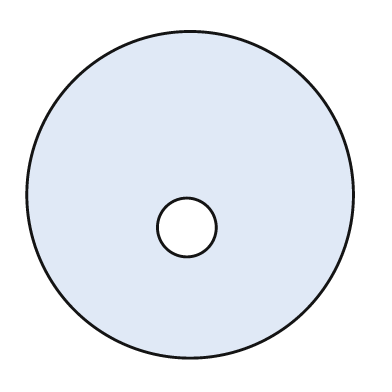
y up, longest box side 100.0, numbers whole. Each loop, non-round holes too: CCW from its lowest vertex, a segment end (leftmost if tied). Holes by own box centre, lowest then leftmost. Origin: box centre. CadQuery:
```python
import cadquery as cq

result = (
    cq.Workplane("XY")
    .moveTo(0.0, 0.0)
    .circle(50.0)
    .moveTo(-1.0, -10.0)
    .circle(9.0)
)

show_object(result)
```